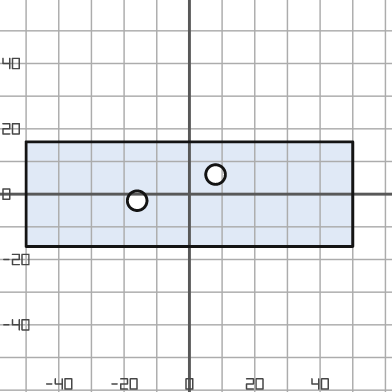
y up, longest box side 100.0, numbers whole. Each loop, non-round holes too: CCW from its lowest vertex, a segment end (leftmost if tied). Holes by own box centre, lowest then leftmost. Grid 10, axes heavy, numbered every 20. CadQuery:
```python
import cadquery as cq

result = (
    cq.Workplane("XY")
    .moveTo(-50.0, -16.0)
    .lineTo(50.0, -16.0)
    .lineTo(50.0, 16.0)
    .lineTo(-50.0, 16.0)
    .close()
    .moveTo(-16.0, -2.0)
    .circle(3.0)
    .moveTo(8.0, 6.0)
    .circle(3.0)
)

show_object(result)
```